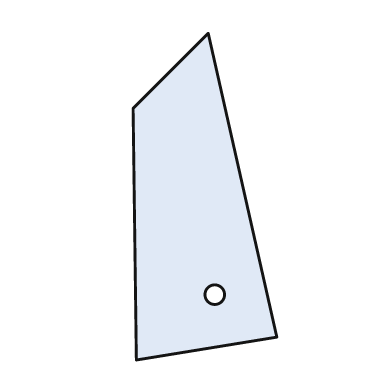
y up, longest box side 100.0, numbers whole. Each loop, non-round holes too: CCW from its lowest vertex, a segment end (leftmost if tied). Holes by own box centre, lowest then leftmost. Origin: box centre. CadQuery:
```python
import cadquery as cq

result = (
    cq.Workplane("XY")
    .moveTo(-21.0, -50.0)
    .lineTo(22.0, -43.0)
    .lineTo(1.0, 50.0)
    .lineTo(-22.0, 27.0)
    .close()
    .moveTo(3.0, -30.0)
    .circle(3.0)
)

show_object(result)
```